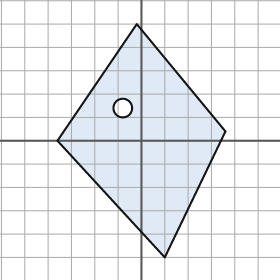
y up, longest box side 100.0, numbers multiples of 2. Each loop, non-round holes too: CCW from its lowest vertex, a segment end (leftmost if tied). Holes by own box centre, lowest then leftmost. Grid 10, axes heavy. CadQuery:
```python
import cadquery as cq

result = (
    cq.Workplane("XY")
    .moveTo(10.0, -50.0)
    .lineTo(36.0, 4.0)
    .lineTo(-2.0, 50.0)
    .lineTo(-36.0, 0.0)
    .close()
    .moveTo(-8.0, 14.0)
    .circle(4.0)
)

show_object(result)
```